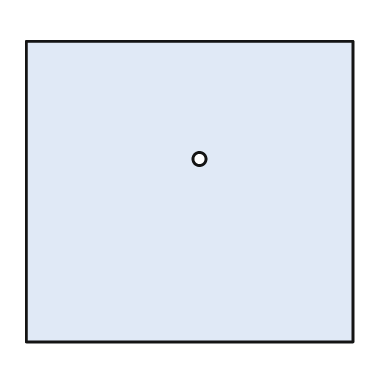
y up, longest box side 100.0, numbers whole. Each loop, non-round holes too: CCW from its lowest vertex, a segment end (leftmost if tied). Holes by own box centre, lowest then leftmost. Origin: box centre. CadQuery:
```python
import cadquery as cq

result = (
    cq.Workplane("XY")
    .moveTo(-50.0, -46.0)
    .lineTo(50.0, -46.0)
    .lineTo(50.0, 46.0)
    .lineTo(-50.0, 46.0)
    .close()
    .moveTo(3.0, 10.0)
    .circle(2.0)
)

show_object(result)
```